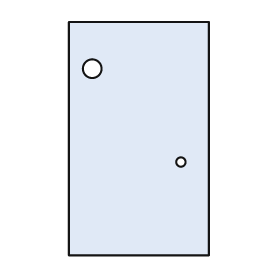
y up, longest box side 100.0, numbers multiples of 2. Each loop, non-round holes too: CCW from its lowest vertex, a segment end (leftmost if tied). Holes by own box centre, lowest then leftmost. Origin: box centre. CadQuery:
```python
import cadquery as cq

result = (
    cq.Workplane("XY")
    .moveTo(-30.0, -50.0)
    .lineTo(30.0, -50.0)
    .lineTo(30.0, 50.0)
    .lineTo(-30.0, 50.0)
    .close()
    .moveTo(18.0, -10.0)
    .circle(2.0)
    .moveTo(-20.0, 30.0)
    .circle(4.0)
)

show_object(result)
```